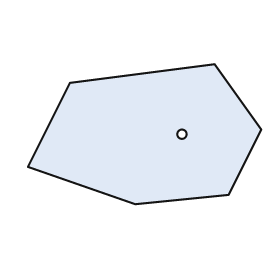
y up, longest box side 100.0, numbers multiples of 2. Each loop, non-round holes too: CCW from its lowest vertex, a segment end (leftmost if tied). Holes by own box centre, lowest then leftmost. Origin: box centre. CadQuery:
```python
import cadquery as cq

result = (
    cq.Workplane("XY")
    .moveTo(-4.0, -30.0)
    .lineTo(36.0, -26.0)
    .lineTo(50.0, 2.0)
    .lineTo(30.0, 30.0)
    .lineTo(-32.0, 22.0)
    .lineTo(-50.0, -14.0)
    .close()
    .moveTo(16.0, 0.0)
    .circle(2.0)
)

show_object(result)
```